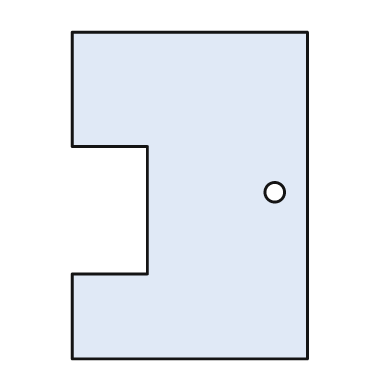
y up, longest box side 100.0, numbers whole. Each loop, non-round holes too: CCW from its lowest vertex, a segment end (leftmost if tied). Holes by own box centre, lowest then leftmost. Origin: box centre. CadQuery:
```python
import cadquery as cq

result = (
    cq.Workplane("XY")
    .moveTo(-36.0, -50.0)
    .lineTo(36.0, -50.0)
    .lineTo(36.0, 50.0)
    .lineTo(-36.0, 50.0)
    .lineTo(-36.0, 15.0)
    .lineTo(-13.0, 15.0)
    .lineTo(-13.0, -24.0)
    .lineTo(-36.0, -24.0)
    .close()
    .moveTo(26.0, 1.0)
    .circle(3.0)
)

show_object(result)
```